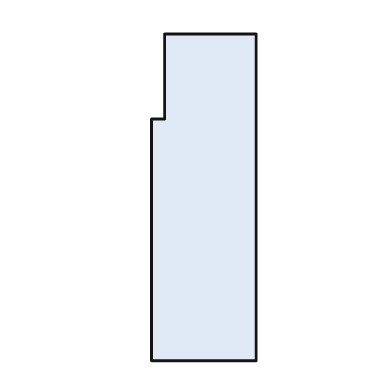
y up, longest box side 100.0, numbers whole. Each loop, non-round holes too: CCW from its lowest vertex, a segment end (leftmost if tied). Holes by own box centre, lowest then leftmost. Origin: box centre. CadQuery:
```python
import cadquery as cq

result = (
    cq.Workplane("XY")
    .moveTo(-16.0, -50.0)
    .lineTo(16.0, -50.0)
    .lineTo(16.0, 50.0)
    .lineTo(-12.0, 50.0)
    .lineTo(-12.0, 24.0)
    .lineTo(-16.0, 24.0)
    .close()
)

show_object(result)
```